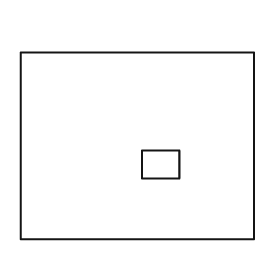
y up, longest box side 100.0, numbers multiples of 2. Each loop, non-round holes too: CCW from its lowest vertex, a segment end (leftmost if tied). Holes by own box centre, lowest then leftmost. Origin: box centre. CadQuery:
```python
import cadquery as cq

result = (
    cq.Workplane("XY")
    .moveTo(-50.0, -40.0)
    .lineTo(50.0, -40.0)
    .lineTo(50.0, 40.0)
    .lineTo(-50.0, 40.0)
    .close()
    .moveTo(2.0, -14.0)
    .lineTo(18.0, -14.0)
    .lineTo(18.0, -2.0)
    .lineTo(2.0, -2.0)
    .close()
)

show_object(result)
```